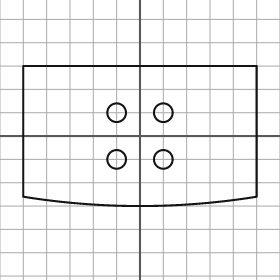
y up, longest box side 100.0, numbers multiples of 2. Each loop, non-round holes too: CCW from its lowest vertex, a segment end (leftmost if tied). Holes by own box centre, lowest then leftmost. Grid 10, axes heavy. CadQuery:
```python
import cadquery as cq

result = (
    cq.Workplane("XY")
    .moveTo(-50.0, -26.0)
    .threePointArc((0.0, -30.0), (50.0, -26.0))
    .lineTo(50.0, 30.0)
    .lineTo(-50.0, 30.0)
    .close()
    .moveTo(-10.0, -10.0)
    .circle(4.0)
    .moveTo(10.0, -10.0)
    .circle(4.0)
    .moveTo(-10.0, 10.0)
    .circle(4.0)
    .moveTo(10.0, 10.0)
    .circle(4.0)
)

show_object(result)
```